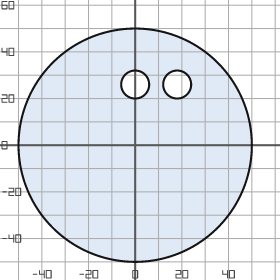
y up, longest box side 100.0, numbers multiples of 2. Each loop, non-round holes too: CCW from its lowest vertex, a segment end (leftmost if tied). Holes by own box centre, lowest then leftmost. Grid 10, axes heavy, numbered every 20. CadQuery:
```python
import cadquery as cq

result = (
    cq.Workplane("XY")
    .moveTo(0.0, 0.0)
    .circle(50.0)
    .moveTo(0.0, 26.0)
    .circle(6.0)
    .moveTo(18.0, 26.0)
    .circle(6.0)
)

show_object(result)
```